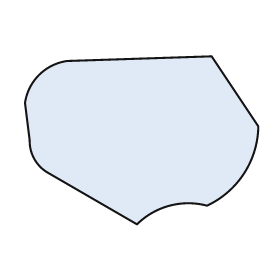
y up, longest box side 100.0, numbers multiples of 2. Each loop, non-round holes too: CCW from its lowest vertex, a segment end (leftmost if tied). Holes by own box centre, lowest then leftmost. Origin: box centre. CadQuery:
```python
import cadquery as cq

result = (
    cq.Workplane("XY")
    .moveTo(-2.0, -36.0)
    .threePointArc((12.0, -28.0), (28.0, -28.0))
    .threePointArc((44.0, -14.0), (50.0, 6.0))
    .lineTo(30.0, 36.0)
    .lineTo(-32.0, 34.0)
    .threePointArc((-44.0, 28.0), (-50.0, 16.0))
    .lineTo(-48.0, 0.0)
    .threePointArc((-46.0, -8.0), (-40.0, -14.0))
    .close()
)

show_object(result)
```